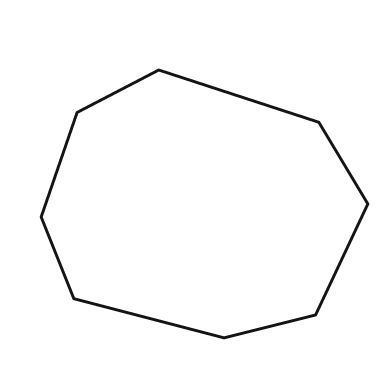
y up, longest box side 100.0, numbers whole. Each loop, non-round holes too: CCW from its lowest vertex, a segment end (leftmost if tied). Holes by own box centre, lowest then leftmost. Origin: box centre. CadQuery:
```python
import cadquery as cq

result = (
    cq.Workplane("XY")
    .moveTo(6.0, -41.0)
    .lineTo(34.0, -34.0)
    .lineTo(50.0, 0.0)
    .lineTo(35.0, 25.0)
    .lineTo(-14.0, 41.0)
    .lineTo(-39.0, 28.0)
    .lineTo(-50.0, -4.0)
    .lineTo(-40.0, -29.0)
    .close()
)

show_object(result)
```